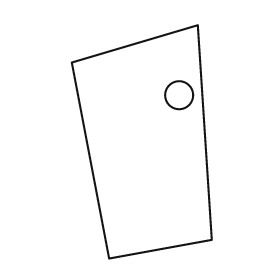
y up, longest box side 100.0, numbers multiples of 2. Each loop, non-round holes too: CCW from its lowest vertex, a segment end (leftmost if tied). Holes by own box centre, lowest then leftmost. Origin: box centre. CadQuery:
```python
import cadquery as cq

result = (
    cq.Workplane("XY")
    .moveTo(-14.0, -50.0)
    .lineTo(30.0, -42.0)
    .lineTo(24.0, 50.0)
    .lineTo(-30.0, 34.0)
    .close()
    .moveTo(16.0, 20.0)
    .circle(6.0)
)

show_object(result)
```